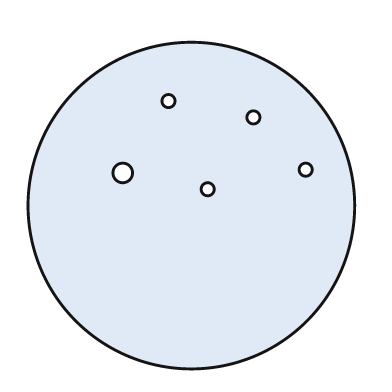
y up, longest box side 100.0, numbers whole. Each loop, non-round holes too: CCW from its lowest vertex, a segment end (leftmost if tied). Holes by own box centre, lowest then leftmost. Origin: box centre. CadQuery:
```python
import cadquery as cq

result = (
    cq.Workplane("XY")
    .moveTo(0.0, 0.0)
    .circle(50.0)
    .moveTo(5.0, 5.0)
    .circle(2.0)
    .moveTo(-21.0, 10.0)
    .circle(3.0)
    .moveTo(35.0, 11.0)
    .circle(2.0)
    .moveTo(19.0, 27.0)
    .circle(2.0)
    .moveTo(-7.0, 32.0)
    .circle(2.0)
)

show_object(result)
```